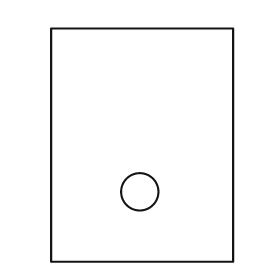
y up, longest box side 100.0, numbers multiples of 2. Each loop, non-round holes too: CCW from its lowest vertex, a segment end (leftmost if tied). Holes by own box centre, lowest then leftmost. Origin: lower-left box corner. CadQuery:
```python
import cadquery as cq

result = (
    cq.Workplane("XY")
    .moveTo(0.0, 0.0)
    .lineTo(78.0, 0.0)
    .lineTo(78.0, 100.0)
    .lineTo(0.0, 100.0)
    .close()
    .moveTo(38.0, 30.0)
    .circle(8.0)
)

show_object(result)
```